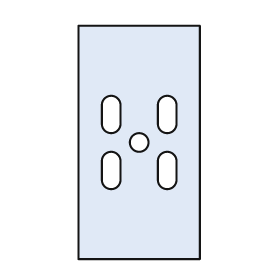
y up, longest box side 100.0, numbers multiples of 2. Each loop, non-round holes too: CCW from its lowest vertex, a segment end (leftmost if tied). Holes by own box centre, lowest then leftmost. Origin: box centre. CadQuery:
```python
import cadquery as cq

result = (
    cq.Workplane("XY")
    .moveTo(-26.0, -50.0)
    .lineTo(26.0, -50.0)
    .lineTo(26.0, 50.0)
    .lineTo(-26.0, 50.0)
    .close()
    .moveTo(-16.0, -16.0)
    .threePointArc((-12.0, -20.0), (-8.0, -16.0))
    .lineTo(-8.0, -8.0)
    .threePointArc((-12.0, -4.0), (-16.0, -8.0))
    .close()
    .moveTo(8.0, -16.0)
    .threePointArc((12.0, -20.0), (16.0, -16.0))
    .lineTo(16.0, -8.0)
    .threePointArc((12.0, -4.0), (8.0, -8.0))
    .close()
    .moveTo(0.0, 0.0)
    .circle(4.0)
    .moveTo(-16.0, 8.0)
    .threePointArc((-12.0, 4.0), (-8.0, 8.0))
    .lineTo(-8.0, 16.0)
    .threePointArc((-12.0, 20.0), (-16.0, 16.0))
    .close()
    .moveTo(8.0, 8.0)
    .threePointArc((12.0, 4.0), (16.0, 8.0))
    .lineTo(16.0, 16.0)
    .threePointArc((12.0, 20.0), (8.0, 16.0))
    .close()
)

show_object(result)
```